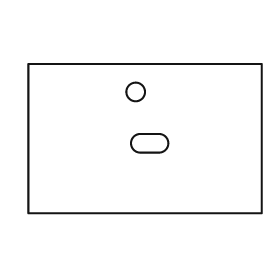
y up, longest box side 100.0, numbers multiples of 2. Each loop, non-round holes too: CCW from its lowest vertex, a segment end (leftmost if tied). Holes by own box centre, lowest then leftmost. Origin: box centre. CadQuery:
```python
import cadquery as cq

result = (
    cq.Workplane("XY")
    .moveTo(-50.0, -32.0)
    .lineTo(50.0, -32.0)
    .lineTo(50.0, 32.0)
    .lineTo(-50.0, 32.0)
    .close()
    .moveTo(-2.0, -6.0)
    .lineTo(6.0, -6.0)
    .threePointArc((10.0, -2.0), (6.0, 2.0))
    .lineTo(-2.0, 2.0)
    .threePointArc((-6.0, -2.0), (-2.0, -6.0))
    .close()
    .moveTo(-4.0, 20.0)
    .circle(4.0)
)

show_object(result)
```